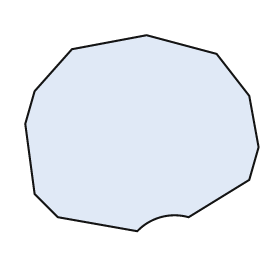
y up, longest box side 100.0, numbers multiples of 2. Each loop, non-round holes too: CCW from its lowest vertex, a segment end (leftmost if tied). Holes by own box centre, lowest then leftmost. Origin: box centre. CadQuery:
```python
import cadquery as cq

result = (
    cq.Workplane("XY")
    .moveTo(-2.0, -42.0)
    .threePointArc((8.0, -36.0), (20.0, -36.0))
    .lineTo(46.0, -20.0)
    .lineTo(50.0, -6.0)
    .lineTo(46.0, 16.0)
    .lineTo(32.0, 34.0)
    .lineTo(2.0, 42.0)
    .lineTo(-30.0, 36.0)
    .lineTo(-46.0, 18.0)
    .lineTo(-50.0, 4.0)
    .lineTo(-46.0, -26.0)
    .lineTo(-36.0, -36.0)
    .close()
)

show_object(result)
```